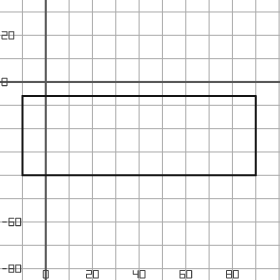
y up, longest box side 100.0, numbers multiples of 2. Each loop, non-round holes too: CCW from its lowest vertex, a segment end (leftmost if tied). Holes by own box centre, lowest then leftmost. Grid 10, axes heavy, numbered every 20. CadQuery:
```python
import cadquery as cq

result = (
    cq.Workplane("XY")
    .moveTo(-10.0, -40.0)
    .lineTo(90.0, -40.0)
    .lineTo(90.0, -6.0)
    .lineTo(-10.0, -6.0)
    .close()
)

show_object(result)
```